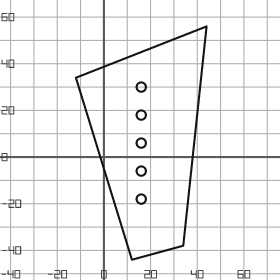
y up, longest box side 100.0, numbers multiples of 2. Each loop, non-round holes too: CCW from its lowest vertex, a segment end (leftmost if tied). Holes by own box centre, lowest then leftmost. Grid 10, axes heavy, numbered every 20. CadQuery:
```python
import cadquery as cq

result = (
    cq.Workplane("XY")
    .moveTo(12.0, -44.0)
    .lineTo(34.0, -38.0)
    .lineTo(44.0, 56.0)
    .lineTo(-12.0, 34.0)
    .close()
    .moveTo(16.0, -18.0)
    .circle(2.0)
    .moveTo(16.0, -6.0)
    .circle(2.0)
    .moveTo(16.0, 6.0)
    .circle(2.0)
    .moveTo(16.0, 18.0)
    .circle(2.0)
    .moveTo(16.0, 30.0)
    .circle(2.0)
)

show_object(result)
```